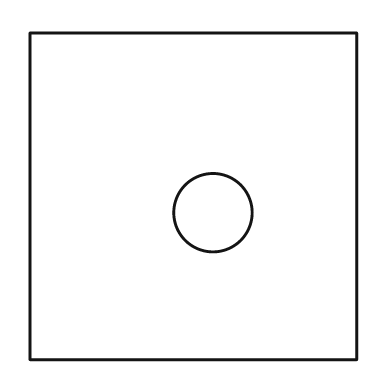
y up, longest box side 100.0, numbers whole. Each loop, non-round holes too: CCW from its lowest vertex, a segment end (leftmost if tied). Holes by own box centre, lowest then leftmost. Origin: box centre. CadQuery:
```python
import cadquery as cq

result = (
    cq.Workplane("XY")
    .moveTo(-50.0, -50.0)
    .lineTo(50.0, -50.0)
    .lineTo(50.0, 50.0)
    .lineTo(-50.0, 50.0)
    .close()
    .moveTo(6.0, -5.0)
    .circle(12.0)
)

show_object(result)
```